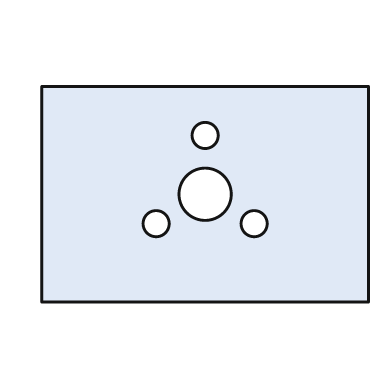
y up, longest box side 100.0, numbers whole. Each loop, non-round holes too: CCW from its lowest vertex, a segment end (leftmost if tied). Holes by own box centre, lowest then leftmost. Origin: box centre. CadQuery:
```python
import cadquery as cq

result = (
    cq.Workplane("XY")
    .moveTo(-50.0, -33.0)
    .lineTo(50.0, -33.0)
    .lineTo(50.0, 33.0)
    .lineTo(-50.0, 33.0)
    .close()
    .moveTo(-15.0, -9.0)
    .circle(4.0)
    .moveTo(15.0, -9.0)
    .circle(4.0)
    .moveTo(0.0, 0.0)
    .circle(8.0)
    .moveTo(0.0, 18.0)
    .circle(4.0)
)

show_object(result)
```